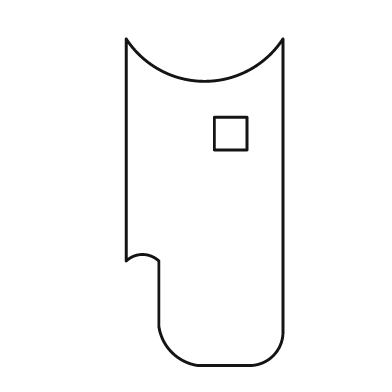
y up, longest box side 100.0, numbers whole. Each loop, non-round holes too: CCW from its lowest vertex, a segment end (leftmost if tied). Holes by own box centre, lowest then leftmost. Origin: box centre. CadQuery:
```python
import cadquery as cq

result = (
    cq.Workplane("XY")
    .moveTo(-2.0, -50.0)
    .lineTo(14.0, -50.0)
    .threePointArc((21.0, -47.0), (24.0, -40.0))
    .lineTo(24.0, 50.0)
    .threePointArc((0.0, 37.0), (-24.0, 50.0))
    .lineTo(-24.0, -18.0)
    .threePointArc((-19.0, -16.0), (-14.0, -18.0))
    .lineTo(-14.0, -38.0)
    .threePointArc((-10.0, -46.0), (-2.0, -50.0))
    .close()
    .moveTo(3.0, 16.0)
    .lineTo(13.0, 16.0)
    .lineTo(13.0, 26.0)
    .lineTo(3.0, 26.0)
    .close()
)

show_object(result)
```